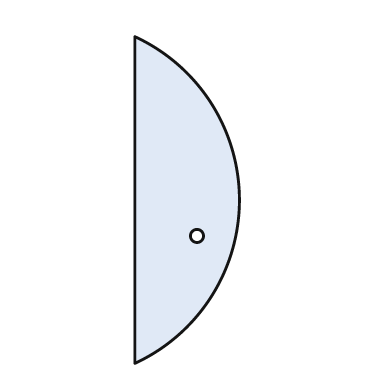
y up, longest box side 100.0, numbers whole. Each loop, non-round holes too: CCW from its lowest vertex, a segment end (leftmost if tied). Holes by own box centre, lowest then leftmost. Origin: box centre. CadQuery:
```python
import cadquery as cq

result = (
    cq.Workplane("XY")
    .moveTo(-16.0, -50.0)
    .threePointArc((16.0, 0.0), (-16.0, 50.0))
    .close()
    .moveTo(3.0, -11.0)
    .circle(2.0)
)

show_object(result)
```